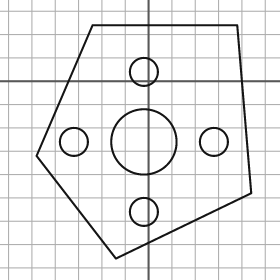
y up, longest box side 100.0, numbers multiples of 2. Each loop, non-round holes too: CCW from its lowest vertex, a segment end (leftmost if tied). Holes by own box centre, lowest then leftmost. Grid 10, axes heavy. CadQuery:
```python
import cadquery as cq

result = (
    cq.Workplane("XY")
    .moveTo(-14.0, -76.0)
    .lineTo(44.0, -48.0)
    .lineTo(38.0, 24.0)
    .lineTo(-24.0, 24.0)
    .lineTo(-48.0, -32.0)
    .close()
    .moveTo(-2.0, -56.0)
    .circle(6.0)
    .moveTo(-32.0, -26.0)
    .circle(6.0)
    .moveTo(-2.0, -26.0)
    .circle(14.0)
    .moveTo(28.0, -26.0)
    .circle(6.0)
    .moveTo(-2.0, 4.0)
    .circle(6.0)
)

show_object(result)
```